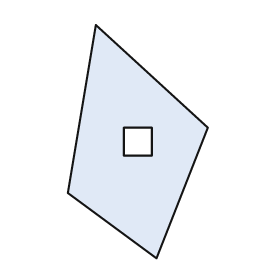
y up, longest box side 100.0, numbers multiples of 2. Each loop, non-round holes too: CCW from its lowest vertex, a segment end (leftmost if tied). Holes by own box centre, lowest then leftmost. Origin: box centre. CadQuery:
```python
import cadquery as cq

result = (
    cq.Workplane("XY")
    .moveTo(8.0, -50.0)
    .lineTo(30.0, 6.0)
    .lineTo(-18.0, 50.0)
    .lineTo(-30.0, -22.0)
    .close()
    .moveTo(-6.0, -6.0)
    .lineTo(6.0, -6.0)
    .lineTo(6.0, 6.0)
    .lineTo(-6.0, 6.0)
    .close()
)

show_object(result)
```